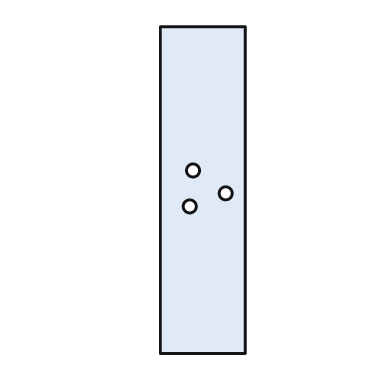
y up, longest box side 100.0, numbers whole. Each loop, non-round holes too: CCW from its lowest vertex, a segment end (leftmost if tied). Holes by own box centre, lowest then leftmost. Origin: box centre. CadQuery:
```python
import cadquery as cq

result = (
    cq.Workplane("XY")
    .moveTo(-13.0, -50.0)
    .lineTo(13.0, -50.0)
    .lineTo(13.0, 50.0)
    .lineTo(-13.0, 50.0)
    .close()
    .moveTo(-4.0, -5.0)
    .circle(2.0)
    .moveTo(7.0, -1.0)
    .circle(2.0)
    .moveTo(-3.0, 6.0)
    .circle(2.0)
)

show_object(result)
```